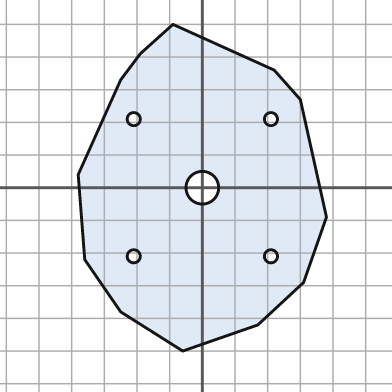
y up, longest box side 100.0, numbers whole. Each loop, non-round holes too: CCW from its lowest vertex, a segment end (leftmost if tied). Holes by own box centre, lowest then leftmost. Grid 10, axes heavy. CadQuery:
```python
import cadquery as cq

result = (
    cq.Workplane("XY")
    .moveTo(-6.0, -50.0)
    .lineTo(17.0, -42.0)
    .lineTo(31.0, -29.0)
    .lineTo(38.0, -9.0)
    .lineTo(30.0, 27.0)
    .lineTo(22.0, 36.0)
    .lineTo(-9.0, 50.0)
    .lineTo(-19.0, 41.0)
    .lineTo(-25.0, 33.0)
    .lineTo(-38.0, 4.0)
    .lineTo(-36.0, -22.0)
    .lineTo(-25.0, -38.0)
    .close()
    .moveTo(-21.0, -21.0)
    .circle(2.0)
    .moveTo(21.0, -21.0)
    .circle(2.0)
    .moveTo(0.0, 0.0)
    .circle(5.0)
    .moveTo(-21.0, 21.0)
    .circle(2.0)
    .moveTo(21.0, 21.0)
    .circle(2.0)
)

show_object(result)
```